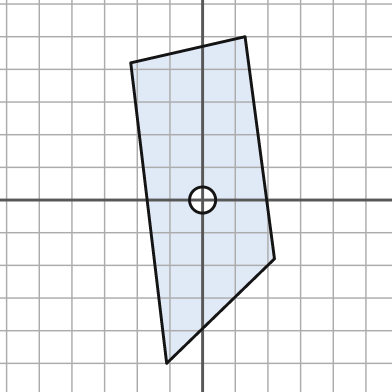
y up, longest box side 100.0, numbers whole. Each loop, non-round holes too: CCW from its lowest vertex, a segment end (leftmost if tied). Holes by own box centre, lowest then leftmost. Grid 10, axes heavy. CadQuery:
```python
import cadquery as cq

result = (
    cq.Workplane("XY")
    .moveTo(-11.0, -50.0)
    .lineTo(22.0, -18.0)
    .lineTo(13.0, 50.0)
    .lineTo(-22.0, 42.0)
    .close()
    .moveTo(0.0, 0.0)
    .circle(4.0)
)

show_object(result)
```